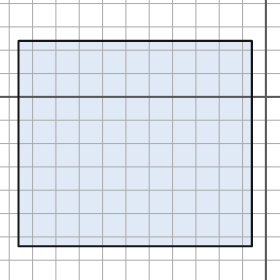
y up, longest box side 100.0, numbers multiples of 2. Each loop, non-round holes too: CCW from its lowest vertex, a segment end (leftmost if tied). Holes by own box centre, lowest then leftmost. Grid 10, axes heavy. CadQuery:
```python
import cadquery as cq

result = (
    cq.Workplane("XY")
    .moveTo(-106.0, -64.0)
    .lineTo(-6.0, -64.0)
    .lineTo(-6.0, 24.0)
    .lineTo(-106.0, 24.0)
    .close()
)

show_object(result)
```